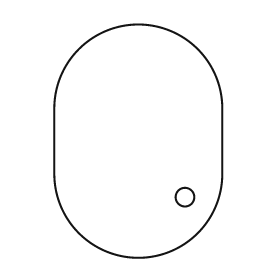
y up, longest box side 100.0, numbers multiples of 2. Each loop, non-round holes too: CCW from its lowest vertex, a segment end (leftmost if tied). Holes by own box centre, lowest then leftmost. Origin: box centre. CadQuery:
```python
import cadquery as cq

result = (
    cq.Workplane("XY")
    .moveTo(-36.0, -14.0)
    .threePointArc((0.0, -50.0), (36.0, -14.0))
    .lineTo(36.0, 14.0)
    .threePointArc((0.0, 50.0), (-36.0, 14.0))
    .close()
    .moveTo(20.0, -24.0)
    .circle(4.0)
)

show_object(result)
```